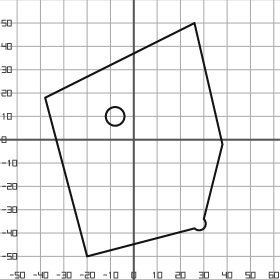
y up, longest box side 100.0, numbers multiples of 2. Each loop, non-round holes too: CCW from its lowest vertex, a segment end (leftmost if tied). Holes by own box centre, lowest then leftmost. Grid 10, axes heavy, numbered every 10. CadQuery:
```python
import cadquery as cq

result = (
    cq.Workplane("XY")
    .moveTo(-20.0, -50.0)
    .lineTo(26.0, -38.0)
    .threePointArc((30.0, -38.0), (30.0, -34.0))
    .lineTo(38.0, -2.0)
    .lineTo(26.0, 50.0)
    .lineTo(-38.0, 18.0)
    .close()
    .moveTo(-8.0, 10.0)
    .circle(4.0)
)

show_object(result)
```